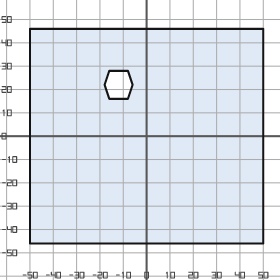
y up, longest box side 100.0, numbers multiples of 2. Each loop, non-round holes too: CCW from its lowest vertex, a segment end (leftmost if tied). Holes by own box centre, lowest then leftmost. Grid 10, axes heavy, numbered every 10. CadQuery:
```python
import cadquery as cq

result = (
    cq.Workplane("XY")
    .moveTo(-50.0, -46.0)
    .lineTo(50.0, -46.0)
    .lineTo(50.0, 46.0)
    .lineTo(-50.0, 46.0)
    .close()
    .moveTo(-16.0, 16.0)
    .lineTo(-8.0, 16.0)
    .lineTo(-6.0, 22.0)
    .lineTo(-8.0, 28.0)
    .lineTo(-16.0, 28.0)
    .lineTo(-18.0, 22.0)
    .close()
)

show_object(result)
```